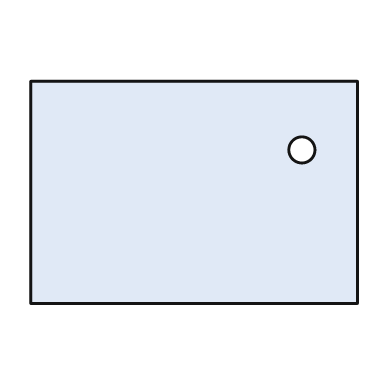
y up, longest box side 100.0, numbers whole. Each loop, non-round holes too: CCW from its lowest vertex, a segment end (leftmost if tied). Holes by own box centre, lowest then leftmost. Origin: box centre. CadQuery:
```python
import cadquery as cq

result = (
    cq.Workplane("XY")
    .moveTo(-50.0, -34.0)
    .lineTo(50.0, -34.0)
    .lineTo(50.0, 34.0)
    .lineTo(-50.0, 34.0)
    .close()
    .moveTo(33.0, 13.0)
    .circle(4.0)
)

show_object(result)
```